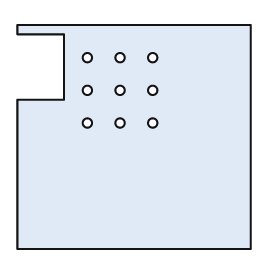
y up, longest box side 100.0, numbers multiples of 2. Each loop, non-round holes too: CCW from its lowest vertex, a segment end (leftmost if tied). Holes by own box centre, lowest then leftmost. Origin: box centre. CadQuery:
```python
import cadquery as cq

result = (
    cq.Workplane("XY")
    .moveTo(-50.0, -48.0)
    .lineTo(50.0, -48.0)
    .lineTo(50.0, 48.0)
    .lineTo(-50.0, 48.0)
    .lineTo(-50.0, 44.0)
    .lineTo(-30.0, 44.0)
    .lineTo(-30.0, 16.0)
    .lineTo(-50.0, 16.0)
    .close()
    .moveTo(-20.0, 6.0)
    .circle(2.0)
    .moveTo(-6.0, 6.0)
    .circle(2.0)
    .moveTo(8.0, 6.0)
    .circle(2.0)
    .moveTo(-20.0, 20.0)
    .circle(2.0)
    .moveTo(-6.0, 20.0)
    .circle(2.0)
    .moveTo(8.0, 20.0)
    .circle(2.0)
    .moveTo(-20.0, 34.0)
    .circle(2.0)
    .moveTo(-6.0, 34.0)
    .circle(2.0)
    .moveTo(8.0, 34.0)
    .circle(2.0)
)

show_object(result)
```